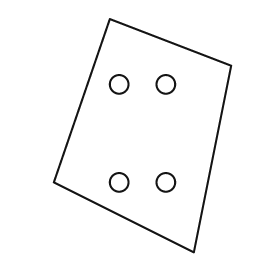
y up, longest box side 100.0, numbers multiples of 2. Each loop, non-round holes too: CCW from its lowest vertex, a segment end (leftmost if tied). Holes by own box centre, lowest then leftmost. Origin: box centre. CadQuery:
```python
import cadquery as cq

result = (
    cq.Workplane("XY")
    .moveTo(22.0, -50.0)
    .lineTo(38.0, 30.0)
    .lineTo(-14.0, 50.0)
    .lineTo(-38.0, -20.0)
    .close()
    .moveTo(-10.0, -20.0)
    .circle(4.0)
    .moveTo(10.0, -20.0)
    .circle(4.0)
    .moveTo(-10.0, 22.0)
    .circle(4.0)
    .moveTo(10.0, 22.0)
    .circle(4.0)
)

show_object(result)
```